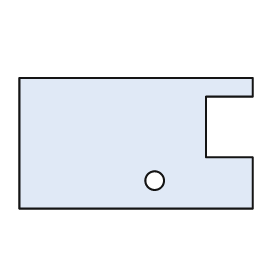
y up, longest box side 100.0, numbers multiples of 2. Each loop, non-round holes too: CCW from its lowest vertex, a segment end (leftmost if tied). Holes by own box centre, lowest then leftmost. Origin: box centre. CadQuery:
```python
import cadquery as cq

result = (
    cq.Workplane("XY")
    .moveTo(-50.0, -28.0)
    .lineTo(50.0, -28.0)
    .lineTo(50.0, -6.0)
    .lineTo(30.0, -6.0)
    .lineTo(30.0, 20.0)
    .lineTo(50.0, 20.0)
    .lineTo(50.0, 28.0)
    .lineTo(-50.0, 28.0)
    .close()
    .moveTo(8.0, -16.0)
    .circle(4.0)
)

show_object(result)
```